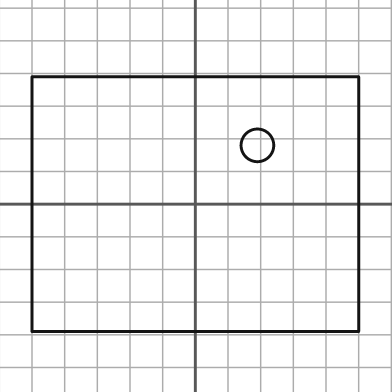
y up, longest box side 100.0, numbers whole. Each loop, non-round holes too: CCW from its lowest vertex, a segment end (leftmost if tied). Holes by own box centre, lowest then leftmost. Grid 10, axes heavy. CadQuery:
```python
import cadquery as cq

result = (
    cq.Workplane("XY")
    .moveTo(-50.0, -39.0)
    .lineTo(50.0, -39.0)
    .lineTo(50.0, 39.0)
    .lineTo(-50.0, 39.0)
    .close()
    .moveTo(19.0, 18.0)
    .circle(5.0)
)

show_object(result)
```